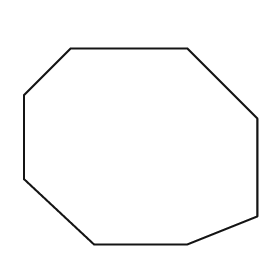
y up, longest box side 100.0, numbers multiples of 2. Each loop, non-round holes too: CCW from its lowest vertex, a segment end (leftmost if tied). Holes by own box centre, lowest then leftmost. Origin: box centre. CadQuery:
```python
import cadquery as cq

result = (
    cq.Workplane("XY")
    .moveTo(-20.0, -42.0)
    .lineTo(20.0, -42.0)
    .lineTo(50.0, -30.0)
    .lineTo(50.0, 12.0)
    .lineTo(20.0, 42.0)
    .lineTo(-30.0, 42.0)
    .lineTo(-50.0, 22.0)
    .lineTo(-50.0, -14.0)
    .close()
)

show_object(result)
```